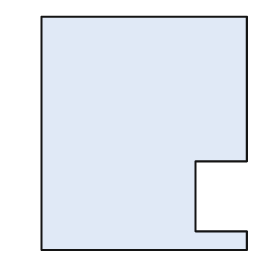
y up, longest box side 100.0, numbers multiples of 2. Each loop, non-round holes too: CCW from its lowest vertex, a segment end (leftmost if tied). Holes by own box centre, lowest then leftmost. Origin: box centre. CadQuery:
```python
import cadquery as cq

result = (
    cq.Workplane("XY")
    .moveTo(-44.0, -50.0)
    .lineTo(44.0, -50.0)
    .lineTo(44.0, -42.0)
    .lineTo(22.0, -42.0)
    .lineTo(22.0, -12.0)
    .lineTo(44.0, -12.0)
    .lineTo(44.0, 50.0)
    .lineTo(-44.0, 50.0)
    .close()
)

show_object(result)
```